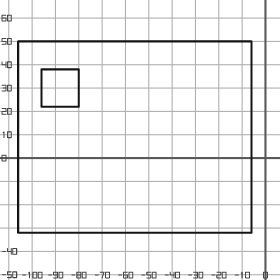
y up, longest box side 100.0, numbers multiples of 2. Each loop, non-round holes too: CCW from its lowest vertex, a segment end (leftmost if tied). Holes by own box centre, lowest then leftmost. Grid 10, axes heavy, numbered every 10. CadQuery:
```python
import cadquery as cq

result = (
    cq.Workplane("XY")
    .moveTo(-106.0, -32.0)
    .lineTo(-6.0, -32.0)
    .lineTo(-6.0, 50.0)
    .lineTo(-106.0, 50.0)
    .close()
    .moveTo(-96.0, 22.0)
    .lineTo(-80.0, 22.0)
    .lineTo(-80.0, 38.0)
    .lineTo(-96.0, 38.0)
    .close()
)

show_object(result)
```